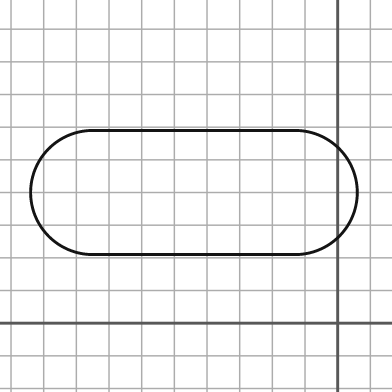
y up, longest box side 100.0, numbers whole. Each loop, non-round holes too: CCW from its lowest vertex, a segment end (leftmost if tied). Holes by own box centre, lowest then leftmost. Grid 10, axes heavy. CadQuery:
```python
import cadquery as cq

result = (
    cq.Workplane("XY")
    .moveTo(-75.0, 21.0)
    .lineTo(-13.0, 21.0)
    .threePointArc((6.0, 40.0), (-13.0, 59.0))
    .lineTo(-75.0, 59.0)
    .threePointArc((-94.0, 40.0), (-75.0, 21.0))
    .close()
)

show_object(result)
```